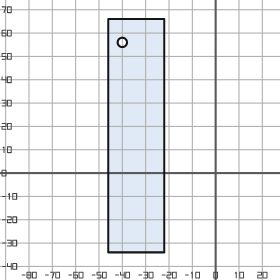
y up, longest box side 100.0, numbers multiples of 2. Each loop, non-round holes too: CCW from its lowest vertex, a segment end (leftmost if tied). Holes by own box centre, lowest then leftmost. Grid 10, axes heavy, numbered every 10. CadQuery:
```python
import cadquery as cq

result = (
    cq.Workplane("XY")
    .moveTo(-46.0, -34.0)
    .lineTo(-22.0, -34.0)
    .lineTo(-22.0, 66.0)
    .lineTo(-46.0, 66.0)
    .close()
    .moveTo(-40.0, 56.0)
    .circle(2.0)
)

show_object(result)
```